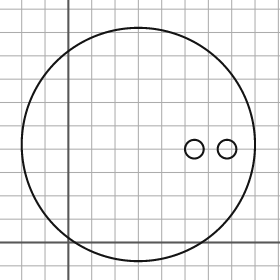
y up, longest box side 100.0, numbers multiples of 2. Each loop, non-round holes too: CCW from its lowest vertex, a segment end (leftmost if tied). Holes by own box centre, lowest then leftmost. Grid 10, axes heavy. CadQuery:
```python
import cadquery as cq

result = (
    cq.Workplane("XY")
    .moveTo(30.0, 42.0)
    .circle(50.0)
    .moveTo(54.0, 40.0)
    .circle(4.0)
    .moveTo(68.0, 40.0)
    .circle(4.0)
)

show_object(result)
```